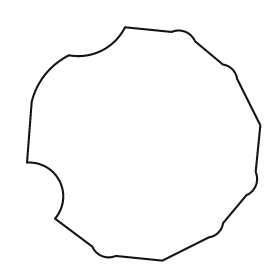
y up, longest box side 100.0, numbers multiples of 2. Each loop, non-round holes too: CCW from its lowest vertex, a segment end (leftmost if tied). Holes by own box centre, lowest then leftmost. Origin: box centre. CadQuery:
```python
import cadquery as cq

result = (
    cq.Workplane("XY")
    .moveTo(8.0, -50.0)
    .lineTo(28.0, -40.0)
    .threePointArc((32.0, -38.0), (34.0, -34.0))
    .lineTo(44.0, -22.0)
    .threePointArc((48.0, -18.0), (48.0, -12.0))
    .lineTo(50.0, 8.0)
    .lineTo(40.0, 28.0)
    .threePointArc((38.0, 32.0), (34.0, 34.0))
    .lineTo(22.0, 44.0)
    .threePointArc((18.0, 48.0), (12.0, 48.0))
    .lineTo(-8.0, 50.0)
    .threePointArc((-18.0, 40.0), (-32.0, 38.0))
    .threePointArc((-42.0, 30.0), (-48.0, 18.0))
    .lineTo(-50.0, -8.0)
    .threePointArc((-36.0, -16.0), (-38.0, -32.0))
    .lineTo(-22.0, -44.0)
    .threePointArc((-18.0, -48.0), (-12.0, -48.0))
    .close()
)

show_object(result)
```